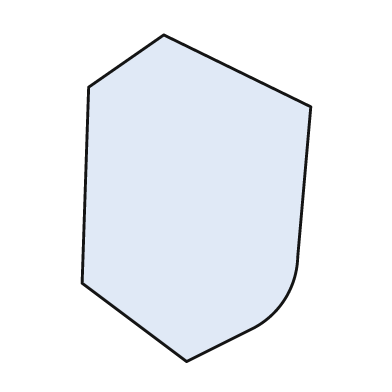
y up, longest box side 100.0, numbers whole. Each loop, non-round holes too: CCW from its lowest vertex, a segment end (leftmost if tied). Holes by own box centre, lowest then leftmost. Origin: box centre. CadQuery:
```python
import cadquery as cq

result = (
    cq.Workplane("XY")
    .moveTo(-3.0, -50.0)
    .lineTo(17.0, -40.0)
    .threePointArc((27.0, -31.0), (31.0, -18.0))
    .lineTo(35.0, 28.0)
    .lineTo(-10.0, 50.0)
    .lineTo(-33.0, 34.0)
    .lineTo(-35.0, -26.0)
    .close()
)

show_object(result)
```